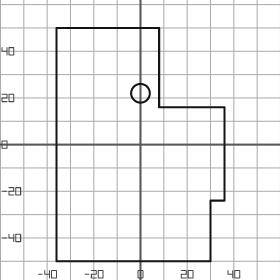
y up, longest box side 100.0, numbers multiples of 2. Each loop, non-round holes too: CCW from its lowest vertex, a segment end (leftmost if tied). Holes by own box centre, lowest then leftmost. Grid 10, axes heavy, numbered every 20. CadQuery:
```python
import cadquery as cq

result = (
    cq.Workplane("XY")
    .moveTo(-36.0, -50.0)
    .lineTo(30.0, -50.0)
    .lineTo(30.0, -24.0)
    .lineTo(36.0, -24.0)
    .lineTo(36.0, 16.0)
    .lineTo(8.0, 16.0)
    .lineTo(8.0, 50.0)
    .lineTo(-36.0, 50.0)
    .close()
    .moveTo(0.0, 22.0)
    .circle(4.0)
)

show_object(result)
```